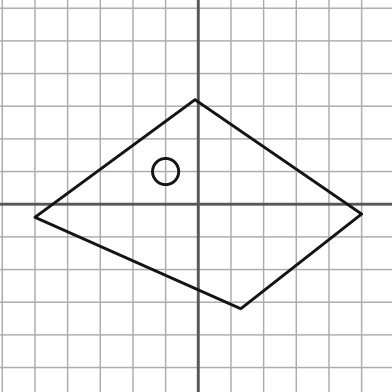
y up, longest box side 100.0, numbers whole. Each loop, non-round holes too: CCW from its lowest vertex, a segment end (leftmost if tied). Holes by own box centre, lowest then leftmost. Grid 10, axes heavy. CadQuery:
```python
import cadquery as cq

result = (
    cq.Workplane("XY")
    .moveTo(13.0, -32.0)
    .lineTo(50.0, -3.0)
    .lineTo(-1.0, 32.0)
    .lineTo(-50.0, -4.0)
    .close()
    .moveTo(-10.0, 10.0)
    .circle(4.0)
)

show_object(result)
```